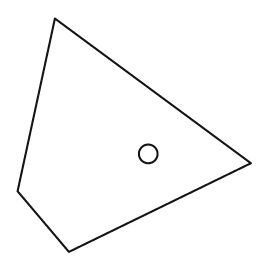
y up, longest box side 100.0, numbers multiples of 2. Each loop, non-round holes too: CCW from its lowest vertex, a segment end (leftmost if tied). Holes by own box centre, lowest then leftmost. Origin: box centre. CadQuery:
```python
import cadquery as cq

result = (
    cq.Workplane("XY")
    .moveTo(-28.0, -50.0)
    .lineTo(50.0, -12.0)
    .lineTo(-34.0, 50.0)
    .lineTo(-50.0, -24.0)
    .close()
    .moveTo(6.0, -8.0)
    .circle(4.0)
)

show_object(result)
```